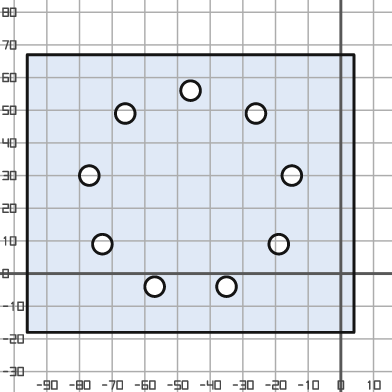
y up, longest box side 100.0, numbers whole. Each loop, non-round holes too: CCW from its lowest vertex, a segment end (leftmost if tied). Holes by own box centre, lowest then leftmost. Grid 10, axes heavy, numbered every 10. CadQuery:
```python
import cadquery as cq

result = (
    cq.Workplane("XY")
    .moveTo(-96.0, -18.0)
    .lineTo(4.0, -18.0)
    .lineTo(4.0, 67.0)
    .lineTo(-96.0, 67.0)
    .close()
    .moveTo(-57.0, -4.0)
    .circle(3.0)
    .moveTo(-35.0, -4.0)
    .circle(3.0)
    .moveTo(-73.0, 9.0)
    .circle(3.0)
    .moveTo(-19.0, 9.0)
    .circle(3.0)
    .moveTo(-77.0, 30.0)
    .circle(3.0)
    .moveTo(-15.0, 30.0)
    .circle(3.0)
    .moveTo(-66.0, 49.0)
    .circle(3.0)
    .moveTo(-26.0, 49.0)
    .circle(3.0)
    .moveTo(-46.0, 56.0)
    .circle(3.0)
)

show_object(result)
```